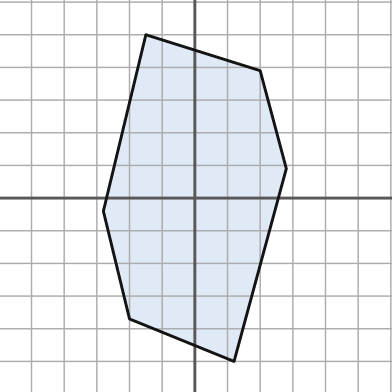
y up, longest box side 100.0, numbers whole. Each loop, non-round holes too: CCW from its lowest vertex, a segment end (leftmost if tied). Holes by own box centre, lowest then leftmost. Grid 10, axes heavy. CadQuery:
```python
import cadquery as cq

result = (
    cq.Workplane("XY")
    .moveTo(12.0, -50.0)
    .lineTo(28.0, 9.0)
    .lineTo(20.0, 39.0)
    .lineTo(-15.0, 50.0)
    .lineTo(-28.0, -4.0)
    .lineTo(-20.0, -37.0)
    .close()
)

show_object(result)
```